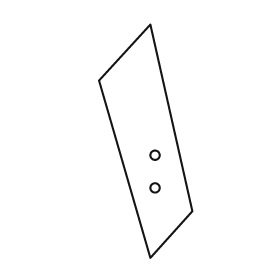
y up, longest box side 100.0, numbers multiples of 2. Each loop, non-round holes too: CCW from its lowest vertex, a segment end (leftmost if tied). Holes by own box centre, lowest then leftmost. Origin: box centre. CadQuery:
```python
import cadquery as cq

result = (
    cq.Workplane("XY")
    .moveTo(2.0, -50.0)
    .lineTo(20.0, -30.0)
    .lineTo(2.0, 50.0)
    .lineTo(-20.0, 26.0)
    .close()
    .moveTo(4.0, -20.0)
    .circle(2.0)
    .moveTo(4.0, -6.0)
    .circle(2.0)
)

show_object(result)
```